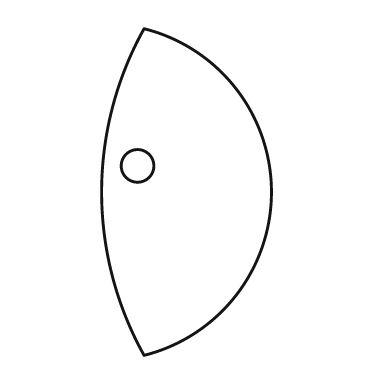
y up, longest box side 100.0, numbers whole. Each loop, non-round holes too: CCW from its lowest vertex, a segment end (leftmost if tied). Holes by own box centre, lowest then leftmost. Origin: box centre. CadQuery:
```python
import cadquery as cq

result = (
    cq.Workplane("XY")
    .moveTo(-13.0, -50.0)
    .threePointArc((26.0, 0.0), (-13.0, 50.0))
    .threePointArc((-26.0, 0.0), (-13.0, -50.0))
    .close()
    .moveTo(-15.0, 8.0)
    .circle(5.0)
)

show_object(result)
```